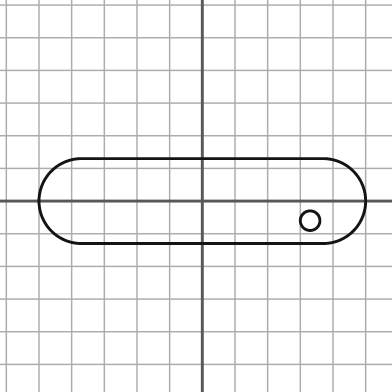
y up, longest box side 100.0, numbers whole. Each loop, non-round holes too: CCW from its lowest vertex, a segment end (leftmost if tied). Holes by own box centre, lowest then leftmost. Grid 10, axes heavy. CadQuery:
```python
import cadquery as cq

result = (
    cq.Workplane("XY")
    .moveTo(-37.0, -13.0)
    .lineTo(37.0, -13.0)
    .threePointArc((50.0, 0.0), (37.0, 13.0))
    .lineTo(-37.0, 13.0)
    .threePointArc((-50.0, 0.0), (-37.0, -13.0))
    .close()
    .moveTo(33.0, -6.0)
    .circle(3.0)
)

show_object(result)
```